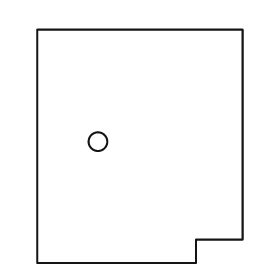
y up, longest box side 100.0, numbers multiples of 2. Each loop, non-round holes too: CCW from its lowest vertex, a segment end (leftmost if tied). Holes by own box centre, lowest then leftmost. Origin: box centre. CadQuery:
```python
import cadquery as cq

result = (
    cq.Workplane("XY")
    .moveTo(-44.0, -50.0)
    .lineTo(24.0, -50.0)
    .lineTo(24.0, -40.0)
    .lineTo(44.0, -40.0)
    .lineTo(44.0, 50.0)
    .lineTo(-44.0, 50.0)
    .close()
    .moveTo(-18.0, 2.0)
    .circle(4.0)
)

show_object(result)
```